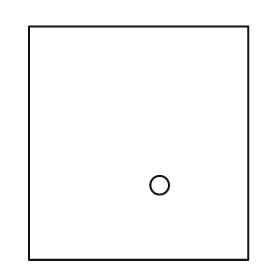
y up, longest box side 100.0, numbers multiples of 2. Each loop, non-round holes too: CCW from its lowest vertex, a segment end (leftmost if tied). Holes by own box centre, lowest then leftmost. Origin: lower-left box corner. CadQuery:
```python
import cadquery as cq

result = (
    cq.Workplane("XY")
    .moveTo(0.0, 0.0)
    .lineTo(94.0, 0.0)
    .lineTo(94.0, 100.0)
    .lineTo(0.0, 100.0)
    .close()
    .moveTo(56.0, 32.0)
    .circle(4.0)
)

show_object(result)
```